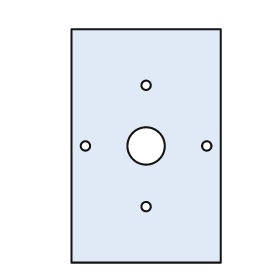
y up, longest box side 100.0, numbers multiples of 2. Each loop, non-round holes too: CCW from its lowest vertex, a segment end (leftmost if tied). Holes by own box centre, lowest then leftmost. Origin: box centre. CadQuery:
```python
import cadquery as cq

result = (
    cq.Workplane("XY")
    .moveTo(-32.0, -50.0)
    .lineTo(32.0, -50.0)
    .lineTo(32.0, 50.0)
    .lineTo(-32.0, 50.0)
    .close()
    .moveTo(0.0, -26.0)
    .circle(2.0)
    .moveTo(-26.0, 0.0)
    .circle(2.0)
    .moveTo(0.0, 0.0)
    .circle(8.0)
    .moveTo(26.0, 0.0)
    .circle(2.0)
    .moveTo(0.0, 26.0)
    .circle(2.0)
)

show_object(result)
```